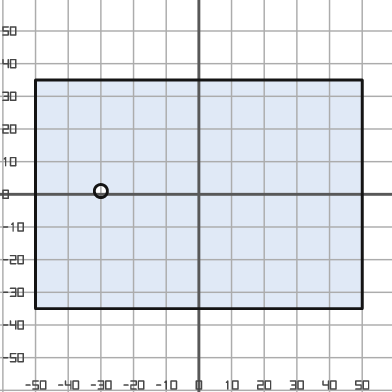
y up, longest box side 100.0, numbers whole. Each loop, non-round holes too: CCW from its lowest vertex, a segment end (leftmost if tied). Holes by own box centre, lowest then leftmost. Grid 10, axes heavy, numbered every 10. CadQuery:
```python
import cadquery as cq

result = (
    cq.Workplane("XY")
    .moveTo(-50.0, -35.0)
    .lineTo(50.0, -35.0)
    .lineTo(50.0, 35.0)
    .lineTo(-50.0, 35.0)
    .close()
    .moveTo(-30.0, 1.0)
    .circle(2.0)
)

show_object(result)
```